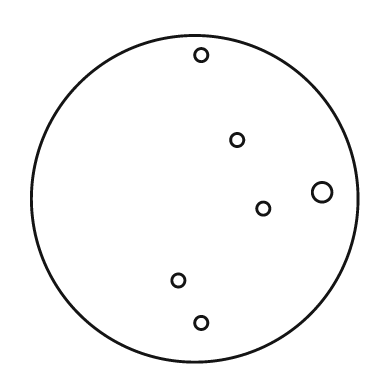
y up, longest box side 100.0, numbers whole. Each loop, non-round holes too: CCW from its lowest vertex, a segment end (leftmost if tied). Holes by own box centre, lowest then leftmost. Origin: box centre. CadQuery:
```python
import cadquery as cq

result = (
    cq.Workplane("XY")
    .moveTo(0.0, 0.0)
    .circle(50.0)
    .moveTo(2.0, -38.0)
    .circle(2.0)
    .moveTo(-5.0, -25.0)
    .circle(2.0)
    .moveTo(21.0, -3.0)
    .circle(2.0)
    .moveTo(39.0, 2.0)
    .circle(3.0)
    .moveTo(13.0, 18.0)
    .circle(2.0)
    .moveTo(2.0, 44.0)
    .circle(2.0)
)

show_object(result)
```